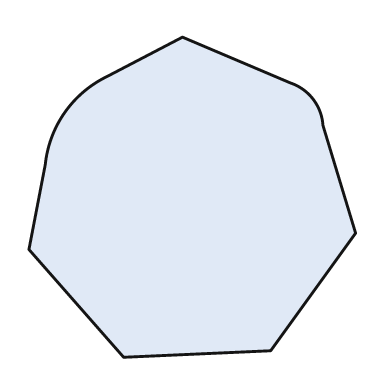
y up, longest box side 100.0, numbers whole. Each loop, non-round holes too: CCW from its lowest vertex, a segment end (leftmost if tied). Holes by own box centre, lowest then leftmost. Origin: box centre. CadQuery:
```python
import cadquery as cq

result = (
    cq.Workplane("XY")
    .moveTo(-21.0, -49.0)
    .lineTo(24.0, -47.0)
    .lineTo(50.0, -11.0)
    .lineTo(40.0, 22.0)
    .threePointArc((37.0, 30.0), (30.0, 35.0))
    .lineTo(-3.0, 49.0)
    .lineTo(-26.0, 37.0)
    .threePointArc((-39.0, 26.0), (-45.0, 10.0))
    .lineTo(-50.0, -16.0)
    .close()
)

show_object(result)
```